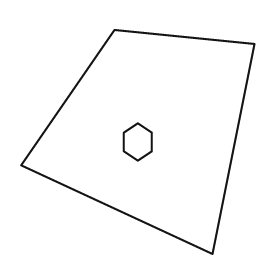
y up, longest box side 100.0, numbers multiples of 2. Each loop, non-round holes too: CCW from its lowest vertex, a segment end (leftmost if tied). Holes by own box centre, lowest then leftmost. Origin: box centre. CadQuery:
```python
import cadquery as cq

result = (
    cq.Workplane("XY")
    .moveTo(32.0, -48.0)
    .lineTo(50.0, 42.0)
    .lineTo(-10.0, 48.0)
    .lineTo(-50.0, -10.0)
    .close()
    .moveTo(0.0, -8.0)
    .lineTo(6.0, -4.0)
    .lineTo(6.0, 4.0)
    .lineTo(0.0, 8.0)
    .lineTo(-6.0, 4.0)
    .lineTo(-6.0, -4.0)
    .close()
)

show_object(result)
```